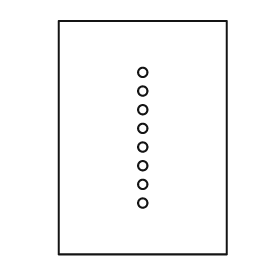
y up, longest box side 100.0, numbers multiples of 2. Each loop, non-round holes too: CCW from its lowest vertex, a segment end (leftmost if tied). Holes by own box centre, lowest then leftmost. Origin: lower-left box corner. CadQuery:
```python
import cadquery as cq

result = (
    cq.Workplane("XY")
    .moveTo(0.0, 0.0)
    .lineTo(72.0, 0.0)
    .lineTo(72.0, 100.0)
    .lineTo(0.0, 100.0)
    .close()
    .moveTo(36.0, 22.0)
    .circle(2.0)
    .moveTo(36.0, 30.0)
    .circle(2.0)
    .moveTo(36.0, 38.0)
    .circle(2.0)
    .moveTo(36.0, 46.0)
    .circle(2.0)
    .moveTo(36.0, 54.0)
    .circle(2.0)
    .moveTo(36.0, 62.0)
    .circle(2.0)
    .moveTo(36.0, 70.0)
    .circle(2.0)
    .moveTo(36.0, 78.0)
    .circle(2.0)
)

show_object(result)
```